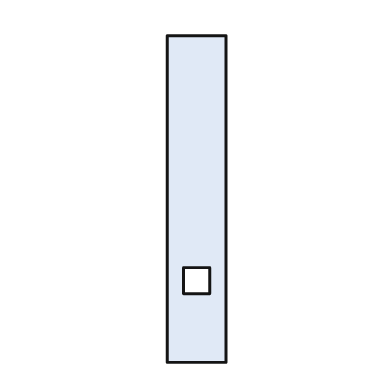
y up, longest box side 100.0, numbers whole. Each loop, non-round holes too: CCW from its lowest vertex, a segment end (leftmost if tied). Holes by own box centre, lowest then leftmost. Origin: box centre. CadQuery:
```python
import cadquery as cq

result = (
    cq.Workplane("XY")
    .moveTo(-9.0, -50.0)
    .lineTo(9.0, -50.0)
    .lineTo(9.0, 50.0)
    .lineTo(-9.0, 50.0)
    .close()
    .moveTo(-4.0, -29.0)
    .lineTo(4.0, -29.0)
    .lineTo(4.0, -21.0)
    .lineTo(-4.0, -21.0)
    .close()
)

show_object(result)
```